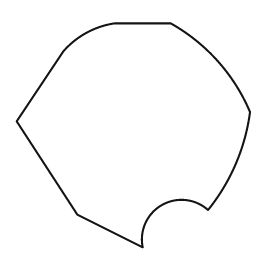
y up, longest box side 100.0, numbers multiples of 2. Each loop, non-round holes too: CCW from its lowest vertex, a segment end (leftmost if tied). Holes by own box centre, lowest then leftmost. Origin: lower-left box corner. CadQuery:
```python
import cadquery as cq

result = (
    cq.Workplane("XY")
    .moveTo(54.0, 0.0)
    .threePointArc((62.0, 18.0), (82.0, 16.0))
    .threePointArc((94.0, 36.0), (100.0, 58.0))
    .threePointArc((86.0, 80.0), (66.0, 96.0))
    .lineTo(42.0, 96.0)
    .threePointArc((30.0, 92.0), (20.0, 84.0))
    .lineTo(0.0, 54.0)
    .lineTo(26.0, 14.0)
    .close()
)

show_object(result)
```